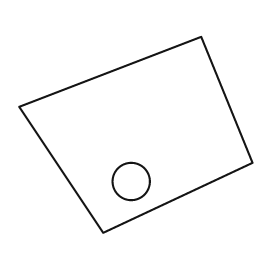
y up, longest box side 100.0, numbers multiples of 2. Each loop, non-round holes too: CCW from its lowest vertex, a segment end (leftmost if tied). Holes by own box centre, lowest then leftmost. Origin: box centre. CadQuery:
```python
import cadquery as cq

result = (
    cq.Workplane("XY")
    .moveTo(-14.0, -42.0)
    .lineTo(50.0, -12.0)
    .lineTo(28.0, 42.0)
    .lineTo(-50.0, 12.0)
    .close()
    .moveTo(-2.0, -20.0)
    .circle(8.0)
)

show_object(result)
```